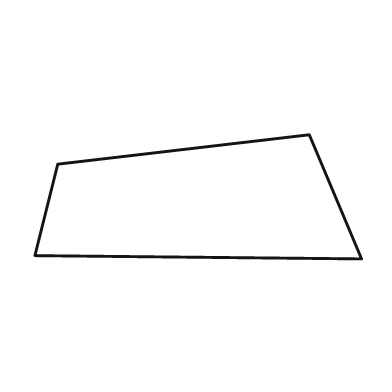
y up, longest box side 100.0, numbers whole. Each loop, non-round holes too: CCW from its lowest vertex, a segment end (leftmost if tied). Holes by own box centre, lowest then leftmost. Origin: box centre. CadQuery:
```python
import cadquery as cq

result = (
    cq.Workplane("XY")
    .moveTo(50.0, -19.0)
    .lineTo(34.0, 19.0)
    .lineTo(-43.0, 10.0)
    .lineTo(-50.0, -18.0)
    .close()
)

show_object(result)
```